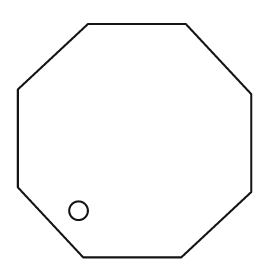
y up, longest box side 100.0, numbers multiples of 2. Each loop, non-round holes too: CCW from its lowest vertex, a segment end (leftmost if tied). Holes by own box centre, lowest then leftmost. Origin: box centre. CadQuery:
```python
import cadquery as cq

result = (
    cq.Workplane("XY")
    .moveTo(-22.0, -50.0)
    .lineTo(20.0, -50.0)
    .lineTo(50.0, -22.0)
    .lineTo(50.0, 20.0)
    .lineTo(22.0, 50.0)
    .lineTo(-20.0, 50.0)
    .lineTo(-50.0, 22.0)
    .lineTo(-50.0, -20.0)
    .close()
    .moveTo(-24.0, -30.0)
    .circle(4.0)
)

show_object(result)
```